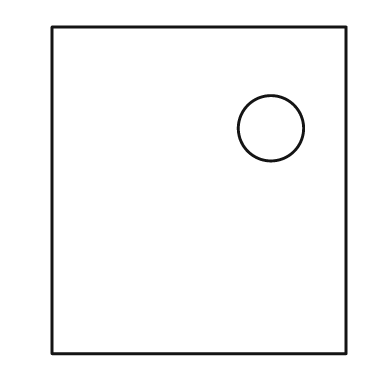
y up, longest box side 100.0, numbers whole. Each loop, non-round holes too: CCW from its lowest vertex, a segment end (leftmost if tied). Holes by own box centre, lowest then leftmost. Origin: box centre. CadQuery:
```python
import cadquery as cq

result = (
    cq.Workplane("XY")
    .moveTo(-45.0, -50.0)
    .lineTo(45.0, -50.0)
    .lineTo(45.0, 50.0)
    .lineTo(-45.0, 50.0)
    .close()
    .moveTo(22.0, 19.0)
    .circle(10.0)
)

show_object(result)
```